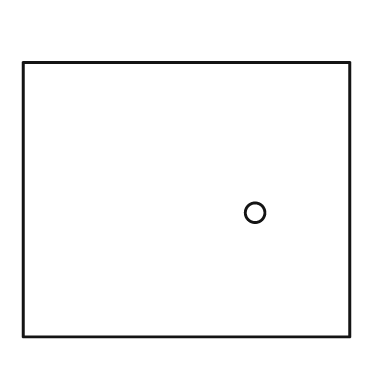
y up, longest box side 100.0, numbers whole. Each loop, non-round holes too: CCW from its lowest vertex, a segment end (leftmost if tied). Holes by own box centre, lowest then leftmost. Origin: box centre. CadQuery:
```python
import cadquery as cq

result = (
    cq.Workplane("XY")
    .moveTo(-50.0, -42.0)
    .lineTo(50.0, -42.0)
    .lineTo(50.0, 42.0)
    .lineTo(-50.0, 42.0)
    .close()
    .moveTo(21.0, -4.0)
    .circle(3.0)
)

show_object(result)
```